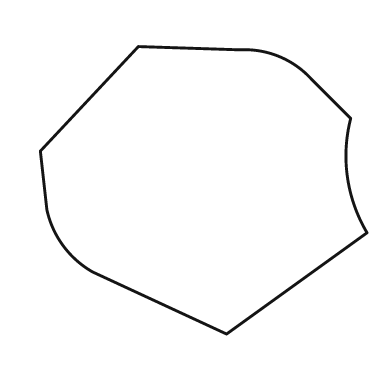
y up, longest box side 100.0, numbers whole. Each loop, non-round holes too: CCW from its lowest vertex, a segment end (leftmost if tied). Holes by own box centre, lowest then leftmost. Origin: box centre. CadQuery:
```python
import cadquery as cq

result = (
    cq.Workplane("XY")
    .moveTo(7.0, -44.0)
    .lineTo(50.0, -13.0)
    .threePointArc((44.0, 4.0), (45.0, 22.0))
    .lineTo(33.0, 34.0)
    .threePointArc((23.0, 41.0), (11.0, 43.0))
    .lineTo(-20.0, 44.0)
    .lineTo(-50.0, 12.0)
    .lineTo(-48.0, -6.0)
    .threePointArc((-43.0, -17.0), (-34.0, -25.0))
    .close()
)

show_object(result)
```